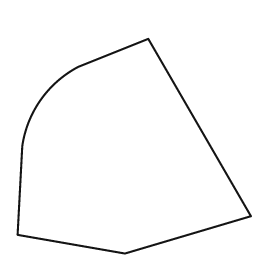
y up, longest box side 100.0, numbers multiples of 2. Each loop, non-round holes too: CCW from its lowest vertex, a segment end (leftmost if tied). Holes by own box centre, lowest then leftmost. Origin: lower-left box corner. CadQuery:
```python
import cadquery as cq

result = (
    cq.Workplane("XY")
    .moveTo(46.0, 0.0)
    .lineTo(100.0, 16.0)
    .lineTo(56.0, 92.0)
    .lineTo(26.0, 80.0)
    .threePointArc((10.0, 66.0), (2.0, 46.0))
    .lineTo(0.0, 8.0)
    .close()
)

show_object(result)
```